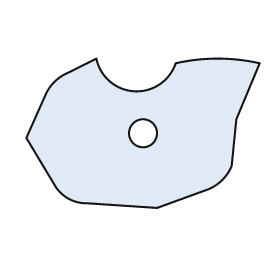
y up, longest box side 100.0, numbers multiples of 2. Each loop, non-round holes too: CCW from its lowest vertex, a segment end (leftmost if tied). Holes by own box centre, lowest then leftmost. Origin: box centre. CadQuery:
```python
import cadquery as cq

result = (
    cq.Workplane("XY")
    .moveTo(6.0, -32.0)
    .lineTo(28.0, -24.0)
    .threePointArc((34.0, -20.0), (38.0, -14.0))
    .lineTo(40.0, 6.0)
    .lineTo(50.0, 30.0)
    .threePointArc((32.0, 32.0), (14.0, 30.0))
    .threePointArc((-4.0, 18.0), (-20.0, 32.0))
    .lineTo(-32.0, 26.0)
    .threePointArc((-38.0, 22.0), (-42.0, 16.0))
    .lineTo(-50.0, -2.0)
    .lineTo(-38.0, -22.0)
    .threePointArc((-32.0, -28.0), (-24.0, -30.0))
    .close()
    .moveTo(0.0, 0.0)
    .circle(6.0)
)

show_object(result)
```